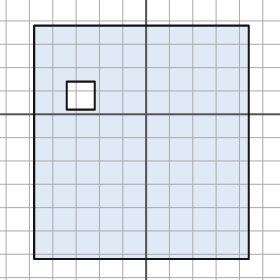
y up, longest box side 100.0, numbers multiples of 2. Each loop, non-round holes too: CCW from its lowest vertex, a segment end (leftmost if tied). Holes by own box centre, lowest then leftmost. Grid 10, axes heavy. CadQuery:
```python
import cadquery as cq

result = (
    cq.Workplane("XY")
    .moveTo(-48.0, -62.0)
    .lineTo(44.0, -62.0)
    .lineTo(44.0, 38.0)
    .lineTo(-48.0, 38.0)
    .close()
    .moveTo(-34.0, 2.0)
    .lineTo(-22.0, 2.0)
    .lineTo(-22.0, 14.0)
    .lineTo(-34.0, 14.0)
    .close()
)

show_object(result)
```